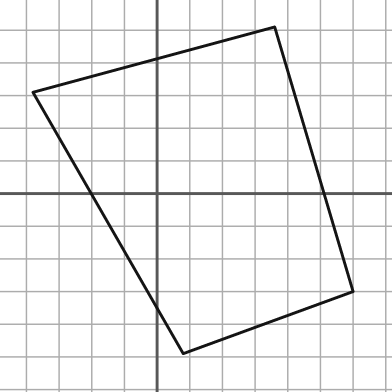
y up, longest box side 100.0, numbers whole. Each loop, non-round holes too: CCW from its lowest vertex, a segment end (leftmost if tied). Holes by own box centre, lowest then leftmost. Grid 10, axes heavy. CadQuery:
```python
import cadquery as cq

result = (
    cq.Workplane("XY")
    .moveTo(8.0, -49.0)
    .lineTo(60.0, -30.0)
    .lineTo(36.0, 51.0)
    .lineTo(-38.0, 31.0)
    .close()
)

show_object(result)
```